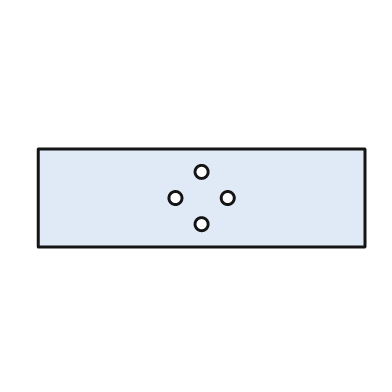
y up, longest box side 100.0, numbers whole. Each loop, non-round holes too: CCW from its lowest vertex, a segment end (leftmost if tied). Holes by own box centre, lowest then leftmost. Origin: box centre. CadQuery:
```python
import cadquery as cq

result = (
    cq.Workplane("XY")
    .moveTo(-50.0, -15.0)
    .lineTo(50.0, -15.0)
    .lineTo(50.0, 15.0)
    .lineTo(-50.0, 15.0)
    .close()
    .moveTo(0.0, -8.0)
    .circle(2.0)
    .moveTo(-8.0, 0.0)
    .circle(2.0)
    .moveTo(8.0, 0.0)
    .circle(2.0)
    .moveTo(0.0, 8.0)
    .circle(2.0)
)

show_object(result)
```